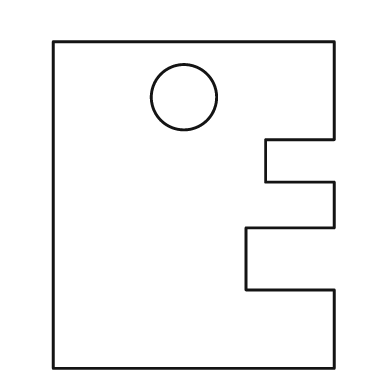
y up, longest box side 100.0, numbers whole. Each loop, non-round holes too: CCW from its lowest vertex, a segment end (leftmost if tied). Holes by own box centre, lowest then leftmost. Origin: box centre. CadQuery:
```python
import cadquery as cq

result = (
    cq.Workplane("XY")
    .moveTo(-43.0, -50.0)
    .lineTo(43.0, -50.0)
    .lineTo(43.0, -26.0)
    .lineTo(16.0, -26.0)
    .lineTo(16.0, -7.0)
    .lineTo(43.0, -7.0)
    .lineTo(43.0, 7.0)
    .lineTo(22.0, 7.0)
    .lineTo(22.0, 20.0)
    .lineTo(43.0, 20.0)
    .lineTo(43.0, 50.0)
    .lineTo(-43.0, 50.0)
    .close()
    .moveTo(-3.0, 33.0)
    .circle(10.0)
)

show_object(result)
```